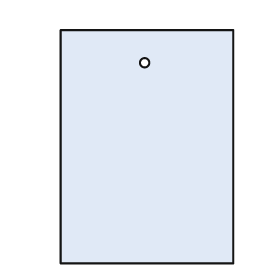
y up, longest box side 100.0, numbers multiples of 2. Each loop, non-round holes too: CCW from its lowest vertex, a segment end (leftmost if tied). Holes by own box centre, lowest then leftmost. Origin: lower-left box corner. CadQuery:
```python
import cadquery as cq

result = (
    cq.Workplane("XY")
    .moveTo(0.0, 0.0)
    .lineTo(74.0, 0.0)
    .lineTo(74.0, 100.0)
    .lineTo(0.0, 100.0)
    .close()
    .moveTo(36.0, 86.0)
    .circle(2.0)
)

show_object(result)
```